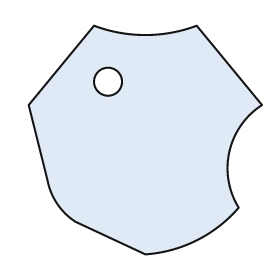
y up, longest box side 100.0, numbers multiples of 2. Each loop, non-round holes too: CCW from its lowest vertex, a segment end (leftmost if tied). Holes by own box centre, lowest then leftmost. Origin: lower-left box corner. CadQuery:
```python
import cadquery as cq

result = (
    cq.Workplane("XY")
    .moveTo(50.0, 0.0)
    .threePointArc((72.0, 6.0), (90.0, 20.0))
    .threePointArc((86.0, 44.0), (100.0, 64.0))
    .lineTo(72.0, 98.0)
    .threePointArc((50.0, 94.0), (28.0, 98.0))
    .lineTo(0.0, 64.0)
    .lineTo(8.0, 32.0)
    .threePointArc((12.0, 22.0), (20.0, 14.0))
    .close()
    .moveTo(34.0, 74.0)
    .circle(6.0)
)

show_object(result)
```